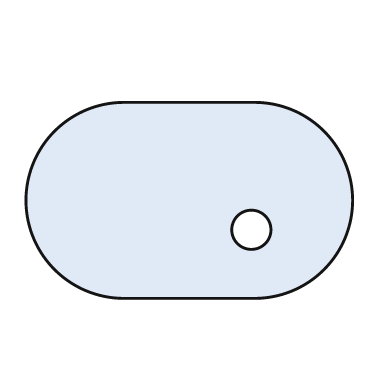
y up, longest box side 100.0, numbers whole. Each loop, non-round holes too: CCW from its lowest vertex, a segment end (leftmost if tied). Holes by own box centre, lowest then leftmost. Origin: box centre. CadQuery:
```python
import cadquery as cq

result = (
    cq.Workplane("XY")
    .moveTo(-20.0, -30.0)
    .lineTo(20.0, -30.0)
    .threePointArc((50.0, 0.0), (20.0, 30.0))
    .lineTo(-20.0, 30.0)
    .threePointArc((-50.0, 0.0), (-20.0, -30.0))
    .close()
    .moveTo(19.0, -9.0)
    .circle(6.0)
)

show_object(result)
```